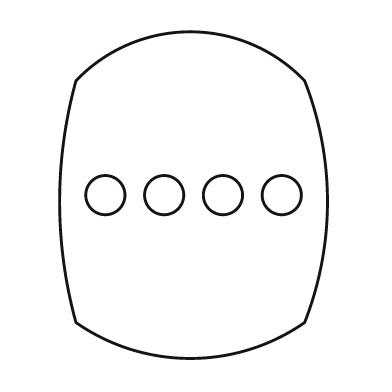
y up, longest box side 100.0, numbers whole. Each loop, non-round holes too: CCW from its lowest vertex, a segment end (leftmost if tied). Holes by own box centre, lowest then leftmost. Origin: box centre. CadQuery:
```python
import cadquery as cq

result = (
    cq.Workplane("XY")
    .moveTo(-36.0, -39.0)
    .threePointArc((-1.0, -50.0), (34.0, -39.0))
    .threePointArc((41.0, -2.0), (34.0, 35.0))
    .threePointArc((-1.0, 50.0), (-36.0, 35.0))
    .threePointArc((-41.0, -2.0), (-36.0, -39.0))
    .close()
    .moveTo(-27.0, 0.0)
    .circle(6.0)
    .moveTo(-9.0, 0.0)
    .circle(6.0)
    .moveTo(9.0, 0.0)
    .circle(6.0)
    .moveTo(27.0, 0.0)
    .circle(6.0)
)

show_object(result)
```